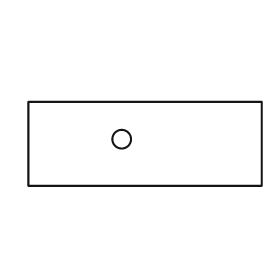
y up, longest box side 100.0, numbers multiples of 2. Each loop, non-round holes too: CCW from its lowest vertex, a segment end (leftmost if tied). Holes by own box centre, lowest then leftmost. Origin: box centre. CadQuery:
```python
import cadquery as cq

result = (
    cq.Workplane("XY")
    .moveTo(-50.0, -18.0)
    .lineTo(50.0, -18.0)
    .lineTo(50.0, 18.0)
    .lineTo(-50.0, 18.0)
    .close()
    .moveTo(-10.0, 2.0)
    .circle(4.0)
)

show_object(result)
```